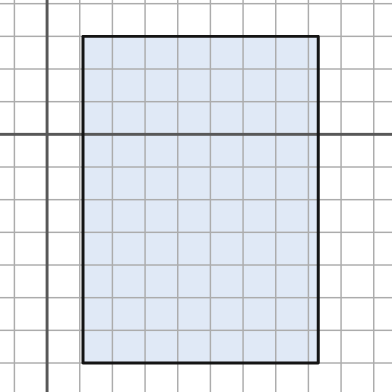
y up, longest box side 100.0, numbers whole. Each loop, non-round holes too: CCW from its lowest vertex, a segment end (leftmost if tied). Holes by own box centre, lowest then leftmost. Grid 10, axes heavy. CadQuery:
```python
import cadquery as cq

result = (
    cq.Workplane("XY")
    .moveTo(11.0, -70.0)
    .lineTo(83.0, -70.0)
    .lineTo(83.0, 30.0)
    .lineTo(11.0, 30.0)
    .close()
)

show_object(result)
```